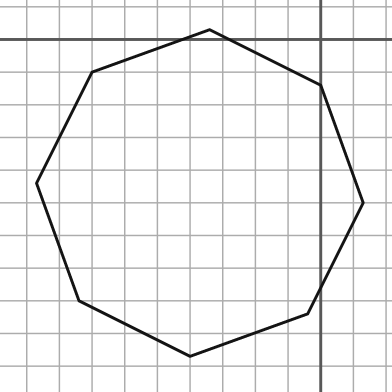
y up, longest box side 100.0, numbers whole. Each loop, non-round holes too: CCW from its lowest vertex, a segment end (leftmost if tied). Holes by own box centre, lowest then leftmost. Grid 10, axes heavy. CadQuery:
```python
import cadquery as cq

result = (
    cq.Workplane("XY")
    .moveTo(-40.0, -97.0)
    .lineTo(-4.0, -84.0)
    .lineTo(13.0, -50.0)
    .lineTo(0.0, -14.0)
    .lineTo(-34.0, 3.0)
    .lineTo(-70.0, -10.0)
    .lineTo(-87.0, -44.0)
    .lineTo(-74.0, -80.0)
    .close()
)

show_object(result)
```